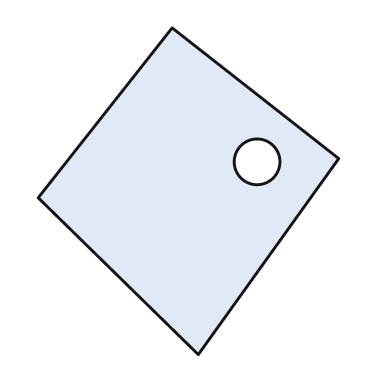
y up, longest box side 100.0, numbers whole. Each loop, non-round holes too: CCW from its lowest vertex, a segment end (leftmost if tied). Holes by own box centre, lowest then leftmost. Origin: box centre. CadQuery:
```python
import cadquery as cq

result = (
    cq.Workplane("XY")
    .moveTo(3.0, -50.0)
    .lineTo(46.0, 10.0)
    .lineTo(-5.0, 50.0)
    .lineTo(-46.0, -2.0)
    .close()
    .moveTo(21.0, 9.0)
    .circle(7.0)
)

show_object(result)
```